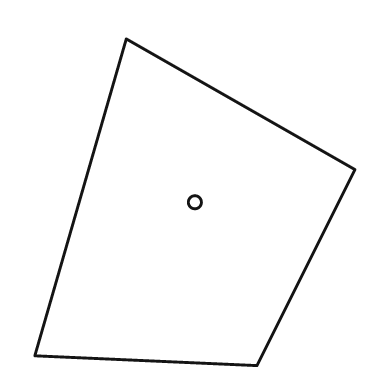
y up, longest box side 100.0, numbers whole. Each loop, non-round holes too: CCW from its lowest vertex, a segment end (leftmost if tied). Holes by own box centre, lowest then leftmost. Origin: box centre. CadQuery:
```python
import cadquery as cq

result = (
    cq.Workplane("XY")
    .moveTo(19.0, -50.0)
    .lineTo(49.0, 10.0)
    .lineTo(-21.0, 50.0)
    .lineTo(-49.0, -47.0)
    .close()
    .moveTo(0.0, 0.0)
    .circle(2.0)
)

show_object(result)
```